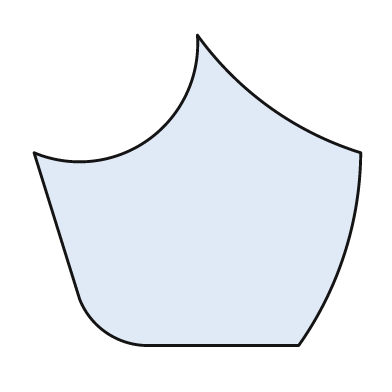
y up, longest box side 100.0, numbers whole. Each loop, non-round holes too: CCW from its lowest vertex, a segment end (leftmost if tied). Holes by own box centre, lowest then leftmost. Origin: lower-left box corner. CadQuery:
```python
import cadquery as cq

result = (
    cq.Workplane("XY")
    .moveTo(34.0, 0.0)
    .lineTo(81.0, 0.0)
    .threePointArc((95.0, 28.0), (100.0, 59.0))
    .threePointArc((72.0, 73.0), (50.0, 95.0))
    .threePointArc((35.0, 63.0), (0.0, 59.0))
    .lineTo(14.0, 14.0)
    .threePointArc((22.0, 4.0), (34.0, 0.0))
    .close()
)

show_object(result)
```